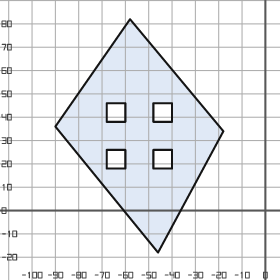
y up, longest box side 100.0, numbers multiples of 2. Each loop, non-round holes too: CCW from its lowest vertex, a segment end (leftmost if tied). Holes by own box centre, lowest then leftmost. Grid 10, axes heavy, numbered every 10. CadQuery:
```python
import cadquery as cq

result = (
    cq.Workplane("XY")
    .moveTo(-46.0, -18.0)
    .lineTo(-18.0, 34.0)
    .lineTo(-58.0, 82.0)
    .lineTo(-90.0, 36.0)
    .close()
    .moveTo(-68.0, 18.0)
    .lineTo(-60.0, 18.0)
    .lineTo(-60.0, 26.0)
    .lineTo(-68.0, 26.0)
    .close()
    .moveTo(-48.0, 18.0)
    .lineTo(-40.0, 18.0)
    .lineTo(-40.0, 26.0)
    .lineTo(-48.0, 26.0)
    .close()
    .moveTo(-68.0, 38.0)
    .lineTo(-60.0, 38.0)
    .lineTo(-60.0, 46.0)
    .lineTo(-68.0, 46.0)
    .close()
    .moveTo(-48.0, 38.0)
    .lineTo(-40.0, 38.0)
    .lineTo(-40.0, 46.0)
    .lineTo(-48.0, 46.0)
    .close()
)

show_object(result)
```